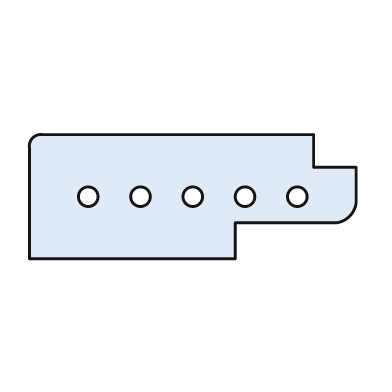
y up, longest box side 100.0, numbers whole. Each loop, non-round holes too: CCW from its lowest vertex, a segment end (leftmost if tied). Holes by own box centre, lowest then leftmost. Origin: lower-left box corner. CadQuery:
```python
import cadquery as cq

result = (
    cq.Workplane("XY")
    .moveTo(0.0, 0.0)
    .lineTo(63.0, 0.0)
    .lineTo(63.0, 11.0)
    .lineTo(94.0, 11.0)
    .threePointArc((98.0, 13.0), (100.0, 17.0))
    .lineTo(100.0, 28.0)
    .lineTo(87.0, 28.0)
    .lineTo(87.0, 38.0)
    .lineTo(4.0, 38.0)
    .threePointArc((1.0, 37.0), (0.0, 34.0))
    .close()
    .moveTo(18.0, 19.0)
    .circle(3.0)
    .moveTo(34.0, 19.0)
    .circle(3.0)
    .moveTo(50.0, 19.0)
    .circle(3.0)
    .moveTo(66.0, 19.0)
    .circle(3.0)
    .moveTo(82.0, 19.0)
    .circle(3.0)
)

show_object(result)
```